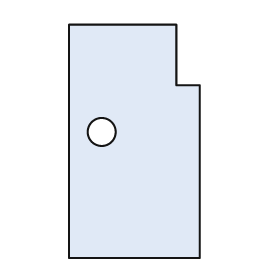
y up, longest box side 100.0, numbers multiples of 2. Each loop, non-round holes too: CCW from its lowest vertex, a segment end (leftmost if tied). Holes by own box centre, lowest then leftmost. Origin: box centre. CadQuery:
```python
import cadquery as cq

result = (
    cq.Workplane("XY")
    .moveTo(-28.0, -50.0)
    .lineTo(28.0, -50.0)
    .lineTo(28.0, 24.0)
    .lineTo(18.0, 24.0)
    .lineTo(18.0, 50.0)
    .lineTo(-28.0, 50.0)
    .close()
    .moveTo(-14.0, 4.0)
    .circle(6.0)
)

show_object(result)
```